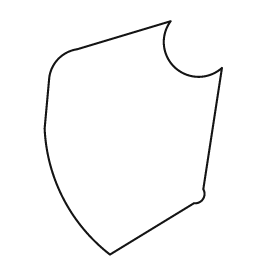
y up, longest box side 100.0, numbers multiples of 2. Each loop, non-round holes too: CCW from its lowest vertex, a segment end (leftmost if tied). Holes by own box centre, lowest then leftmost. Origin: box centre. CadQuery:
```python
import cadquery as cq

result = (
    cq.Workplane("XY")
    .moveTo(-10.0, -50.0)
    .lineTo(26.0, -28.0)
    .threePointArc((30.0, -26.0), (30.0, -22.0))
    .lineTo(38.0, 30.0)
    .threePointArc((18.0, 30.0), (16.0, 50.0))
    .lineTo(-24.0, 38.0)
    .threePointArc((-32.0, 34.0), (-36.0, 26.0))
    .lineTo(-38.0, 4.0)
    .threePointArc((-30.0, -26.0), (-10.0, -50.0))
    .close()
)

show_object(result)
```